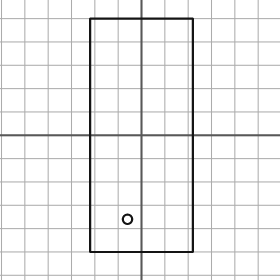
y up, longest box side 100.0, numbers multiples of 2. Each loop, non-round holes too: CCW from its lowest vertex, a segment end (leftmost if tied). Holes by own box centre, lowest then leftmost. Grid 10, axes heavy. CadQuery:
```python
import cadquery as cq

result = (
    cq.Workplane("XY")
    .moveTo(-22.0, -50.0)
    .lineTo(22.0, -50.0)
    .lineTo(22.0, 50.0)
    .lineTo(-22.0, 50.0)
    .close()
    .moveTo(-6.0, -36.0)
    .circle(2.0)
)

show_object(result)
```